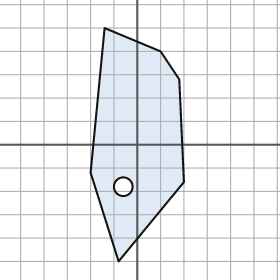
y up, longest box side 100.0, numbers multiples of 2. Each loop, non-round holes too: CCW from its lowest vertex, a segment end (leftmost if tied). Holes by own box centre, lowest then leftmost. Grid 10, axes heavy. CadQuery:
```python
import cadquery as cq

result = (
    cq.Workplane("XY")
    .moveTo(-8.0, -50.0)
    .lineTo(20.0, -16.0)
    .lineTo(18.0, 28.0)
    .lineTo(10.0, 40.0)
    .lineTo(-14.0, 50.0)
    .lineTo(-20.0, -12.0)
    .close()
    .moveTo(-6.0, -18.0)
    .circle(4.0)
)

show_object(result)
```